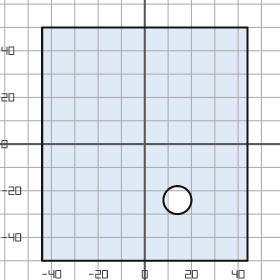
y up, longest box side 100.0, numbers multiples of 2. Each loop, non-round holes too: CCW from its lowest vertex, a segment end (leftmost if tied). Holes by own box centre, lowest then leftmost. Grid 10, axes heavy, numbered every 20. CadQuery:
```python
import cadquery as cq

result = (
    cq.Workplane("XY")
    .moveTo(-44.0, -50.0)
    .lineTo(44.0, -50.0)
    .lineTo(44.0, 50.0)
    .lineTo(-44.0, 50.0)
    .close()
    .moveTo(14.0, -24.0)
    .circle(6.0)
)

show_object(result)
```